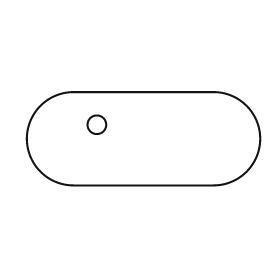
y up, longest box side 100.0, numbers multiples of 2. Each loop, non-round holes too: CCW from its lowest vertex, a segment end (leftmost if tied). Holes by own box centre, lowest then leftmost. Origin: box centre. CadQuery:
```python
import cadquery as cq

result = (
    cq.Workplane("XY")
    .moveTo(-30.0, -20.0)
    .lineTo(30.0, -20.0)
    .threePointArc((50.0, 0.0), (30.0, 20.0))
    .lineTo(-30.0, 20.0)
    .threePointArc((-50.0, 0.0), (-30.0, -20.0))
    .close()
    .moveTo(-20.0, 6.0)
    .circle(4.0)
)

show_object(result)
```